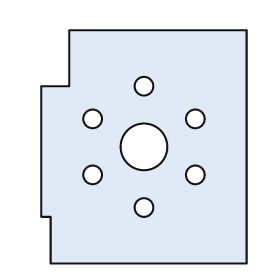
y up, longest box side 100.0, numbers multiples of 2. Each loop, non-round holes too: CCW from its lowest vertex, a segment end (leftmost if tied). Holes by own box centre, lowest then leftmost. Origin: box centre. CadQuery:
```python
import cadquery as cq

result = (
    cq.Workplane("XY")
    .moveTo(-40.0, -50.0)
    .lineTo(44.0, -50.0)
    .lineTo(44.0, 50.0)
    .lineTo(-32.0, 50.0)
    .lineTo(-32.0, 26.0)
    .lineTo(-44.0, 26.0)
    .lineTo(-44.0, -30.0)
    .lineTo(-40.0, -30.0)
    .close()
    .moveTo(0.0, -26.0)
    .circle(4.0)
    .moveTo(-22.0, -12.0)
    .circle(4.0)
    .moveTo(22.0, -12.0)
    .circle(4.0)
    .moveTo(0.0, 0.0)
    .circle(10.0)
    .moveTo(-22.0, 12.0)
    .circle(4.0)
    .moveTo(22.0, 12.0)
    .circle(4.0)
    .moveTo(0.0, 26.0)
    .circle(4.0)
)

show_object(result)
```